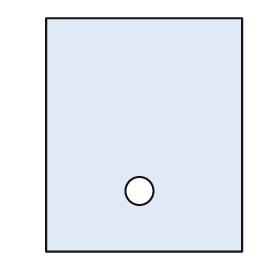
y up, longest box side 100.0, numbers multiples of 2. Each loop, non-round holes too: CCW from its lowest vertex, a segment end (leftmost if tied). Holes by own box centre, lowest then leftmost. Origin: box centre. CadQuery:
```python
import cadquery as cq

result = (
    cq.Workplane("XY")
    .moveTo(-42.0, -50.0)
    .lineTo(42.0, -50.0)
    .lineTo(42.0, 50.0)
    .lineTo(-42.0, 50.0)
    .close()
    .moveTo(-2.0, -24.0)
    .circle(6.0)
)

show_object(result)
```